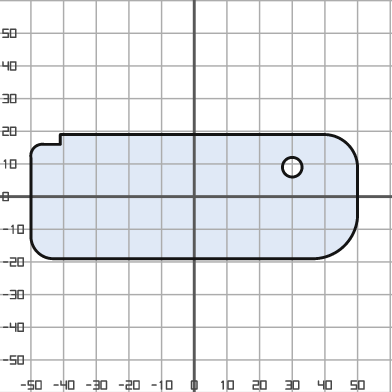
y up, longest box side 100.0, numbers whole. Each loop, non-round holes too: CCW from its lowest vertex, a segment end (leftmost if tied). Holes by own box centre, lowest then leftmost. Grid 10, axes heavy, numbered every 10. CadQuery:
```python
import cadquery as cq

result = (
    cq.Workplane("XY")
    .moveTo(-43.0, -19.0)
    .lineTo(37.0, -19.0)
    .threePointArc((46.0, -15.0), (50.0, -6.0))
    .lineTo(50.0, 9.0)
    .threePointArc((47.0, 16.0), (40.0, 19.0))
    .lineTo(-41.0, 19.0)
    .lineTo(-41.0, 16.0)
    .lineTo(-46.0, 16.0)
    .threePointArc((-49.0, 15.0), (-50.0, 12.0))
    .lineTo(-50.0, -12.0)
    .threePointArc((-48.0, -17.0), (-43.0, -19.0))
    .close()
    .moveTo(30.0, 9.0)
    .circle(3.0)
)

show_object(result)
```